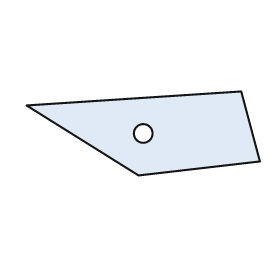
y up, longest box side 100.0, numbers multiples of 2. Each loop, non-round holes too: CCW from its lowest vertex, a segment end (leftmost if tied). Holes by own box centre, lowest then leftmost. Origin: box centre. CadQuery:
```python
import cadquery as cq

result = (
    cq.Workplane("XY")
    .moveTo(-2.0, -18.0)
    .lineTo(50.0, -12.0)
    .lineTo(42.0, 18.0)
    .lineTo(-50.0, 12.0)
    .close()
    .moveTo(0.0, 0.0)
    .circle(4.0)
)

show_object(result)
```